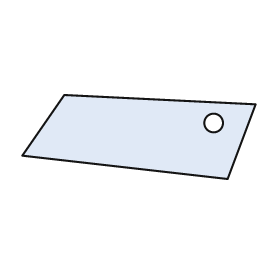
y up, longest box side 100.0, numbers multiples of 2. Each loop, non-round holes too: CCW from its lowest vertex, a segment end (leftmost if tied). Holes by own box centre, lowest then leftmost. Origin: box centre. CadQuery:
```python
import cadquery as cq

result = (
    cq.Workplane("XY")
    .moveTo(38.0, -18.0)
    .lineTo(50.0, 14.0)
    .lineTo(-32.0, 18.0)
    .lineTo(-50.0, -8.0)
    .close()
    .moveTo(32.0, 6.0)
    .circle(4.0)
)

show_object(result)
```